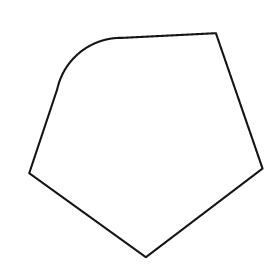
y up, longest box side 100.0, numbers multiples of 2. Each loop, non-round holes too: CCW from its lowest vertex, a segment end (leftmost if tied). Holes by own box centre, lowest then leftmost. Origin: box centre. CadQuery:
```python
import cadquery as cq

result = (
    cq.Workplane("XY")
    .moveTo(0.0, -48.0)
    .lineTo(50.0, -10.0)
    .lineTo(30.0, 48.0)
    .lineTo(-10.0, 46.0)
    .threePointArc((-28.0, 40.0), (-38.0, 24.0))
    .lineTo(-50.0, -12.0)
    .close()
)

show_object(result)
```